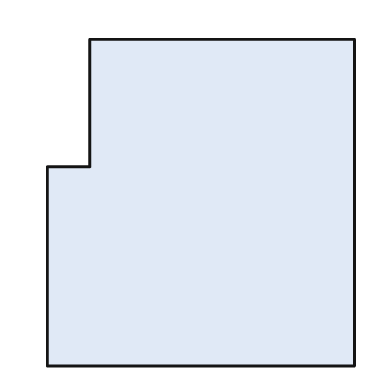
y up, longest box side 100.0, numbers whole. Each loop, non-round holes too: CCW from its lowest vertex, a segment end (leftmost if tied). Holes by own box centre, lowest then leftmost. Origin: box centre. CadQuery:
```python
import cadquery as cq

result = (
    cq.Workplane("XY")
    .moveTo(-47.0, -50.0)
    .lineTo(47.0, -50.0)
    .lineTo(47.0, 50.0)
    .lineTo(-34.0, 50.0)
    .lineTo(-34.0, 11.0)
    .lineTo(-47.0, 11.0)
    .close()
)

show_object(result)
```